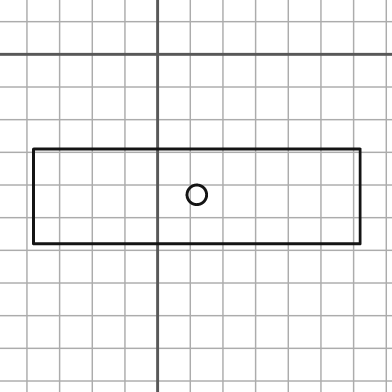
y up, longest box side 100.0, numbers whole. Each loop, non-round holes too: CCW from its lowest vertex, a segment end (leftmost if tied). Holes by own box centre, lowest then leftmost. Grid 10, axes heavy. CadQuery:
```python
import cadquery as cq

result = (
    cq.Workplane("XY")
    .moveTo(-38.0, -58.0)
    .lineTo(62.0, -58.0)
    .lineTo(62.0, -29.0)
    .lineTo(-38.0, -29.0)
    .close()
    .moveTo(12.0, -43.0)
    .circle(3.0)
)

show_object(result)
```